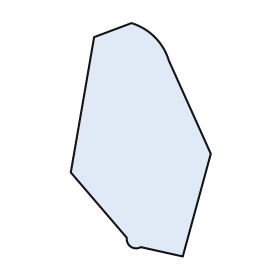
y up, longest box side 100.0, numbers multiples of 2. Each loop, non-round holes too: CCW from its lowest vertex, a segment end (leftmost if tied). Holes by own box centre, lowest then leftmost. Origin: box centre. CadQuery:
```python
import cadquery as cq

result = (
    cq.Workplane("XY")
    .moveTo(18.0, -50.0)
    .lineTo(30.0, -6.0)
    .lineTo(12.0, 34.0)
    .threePointArc((6.0, 44.0), (-4.0, 50.0))
    .lineTo(-20.0, 44.0)
    .lineTo(-30.0, -14.0)
    .lineTo(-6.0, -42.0)
    .threePointArc((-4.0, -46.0), (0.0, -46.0))
    .close()
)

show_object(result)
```